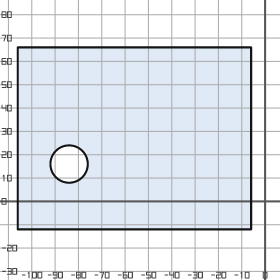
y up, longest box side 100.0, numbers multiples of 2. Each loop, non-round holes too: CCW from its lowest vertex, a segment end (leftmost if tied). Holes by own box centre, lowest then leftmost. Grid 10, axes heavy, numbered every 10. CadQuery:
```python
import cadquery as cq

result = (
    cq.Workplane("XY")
    .moveTo(-106.0, -12.0)
    .lineTo(-6.0, -12.0)
    .lineTo(-6.0, 66.0)
    .lineTo(-106.0, 66.0)
    .close()
    .moveTo(-84.0, 16.0)
    .circle(8.0)
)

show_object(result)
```